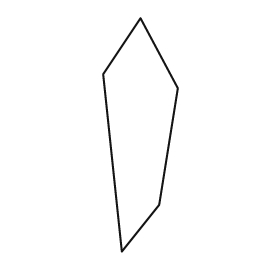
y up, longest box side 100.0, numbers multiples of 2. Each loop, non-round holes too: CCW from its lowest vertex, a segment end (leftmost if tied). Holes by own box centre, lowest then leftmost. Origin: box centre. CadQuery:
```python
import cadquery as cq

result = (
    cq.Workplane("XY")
    .moveTo(-8.0, -50.0)
    .lineTo(8.0, -30.0)
    .lineTo(16.0, 20.0)
    .lineTo(0.0, 50.0)
    .lineTo(-16.0, 26.0)
    .close()
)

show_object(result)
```